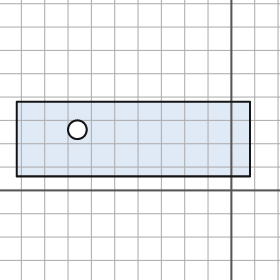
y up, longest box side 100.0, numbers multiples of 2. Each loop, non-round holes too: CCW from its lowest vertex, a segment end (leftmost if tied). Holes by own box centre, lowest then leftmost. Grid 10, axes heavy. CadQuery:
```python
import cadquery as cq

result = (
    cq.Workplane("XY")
    .moveTo(-92.0, 6.0)
    .lineTo(8.0, 6.0)
    .lineTo(8.0, 38.0)
    .lineTo(-92.0, 38.0)
    .close()
    .moveTo(-66.0, 26.0)
    .circle(4.0)
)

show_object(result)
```